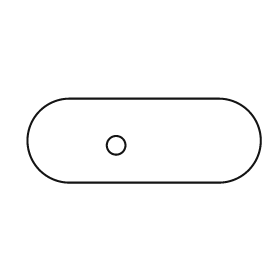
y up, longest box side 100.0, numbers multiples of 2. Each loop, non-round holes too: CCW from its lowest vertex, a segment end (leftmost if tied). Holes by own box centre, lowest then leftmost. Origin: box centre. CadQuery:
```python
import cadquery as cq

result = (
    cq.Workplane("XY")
    .moveTo(-32.0, -18.0)
    .lineTo(32.0, -18.0)
    .threePointArc((50.0, 0.0), (32.0, 18.0))
    .lineTo(-32.0, 18.0)
    .threePointArc((-50.0, 0.0), (-32.0, -18.0))
    .close()
    .moveTo(-12.0, -2.0)
    .circle(4.0)
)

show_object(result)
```